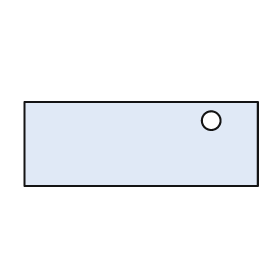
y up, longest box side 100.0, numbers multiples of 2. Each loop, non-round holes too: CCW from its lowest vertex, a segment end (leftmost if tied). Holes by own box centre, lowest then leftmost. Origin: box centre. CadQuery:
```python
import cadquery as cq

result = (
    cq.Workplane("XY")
    .moveTo(-50.0, -18.0)
    .lineTo(50.0, -18.0)
    .lineTo(50.0, 18.0)
    .lineTo(-50.0, 18.0)
    .close()
    .moveTo(30.0, 10.0)
    .circle(4.0)
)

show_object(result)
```